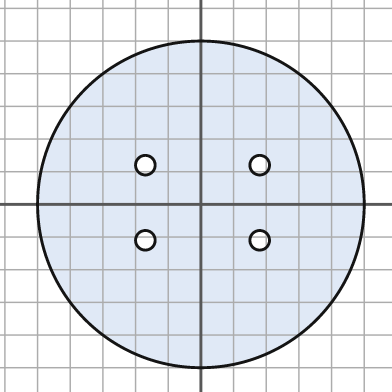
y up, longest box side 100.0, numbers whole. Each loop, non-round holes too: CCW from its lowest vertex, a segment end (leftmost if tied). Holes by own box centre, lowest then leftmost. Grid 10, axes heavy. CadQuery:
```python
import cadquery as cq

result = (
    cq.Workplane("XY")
    .moveTo(0.0, 0.0)
    .circle(50.0)
    .moveTo(-17.0, -11.0)
    .circle(3.0)
    .moveTo(18.0, -11.0)
    .circle(3.0)
    .moveTo(-17.0, 12.0)
    .circle(3.0)
    .moveTo(18.0, 12.0)
    .circle(3.0)
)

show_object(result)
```